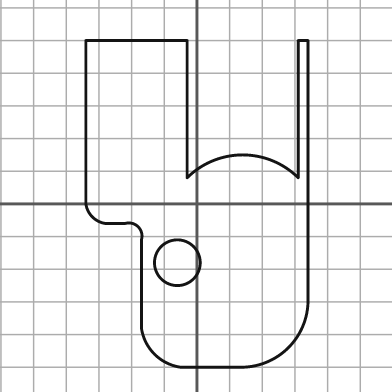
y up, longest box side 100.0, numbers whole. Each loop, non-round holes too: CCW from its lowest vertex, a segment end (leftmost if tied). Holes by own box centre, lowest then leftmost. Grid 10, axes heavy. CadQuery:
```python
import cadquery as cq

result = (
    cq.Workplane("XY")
    .moveTo(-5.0, -50.0)
    .lineTo(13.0, -50.0)
    .threePointArc((28.0, -44.0), (34.0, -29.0))
    .lineTo(34.0, 50.0)
    .lineTo(31.0, 50.0)
    .lineTo(31.0, 8.0)
    .threePointArc((14.0, 15.0), (-3.0, 8.0))
    .lineTo(-3.0, 50.0)
    .lineTo(-34.0, 50.0)
    .lineTo(-34.0, 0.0)
    .threePointArc((-32.0, -4.0), (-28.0, -6.0))
    .lineTo(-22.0, -6.0)
    .threePointArc((-18.0, -7.0), (-17.0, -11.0))
    .lineTo(-17.0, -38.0)
    .threePointArc((-13.0, -46.0), (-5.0, -50.0))
    .close()
    .moveTo(-6.0, -18.0)
    .circle(7.0)
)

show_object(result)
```